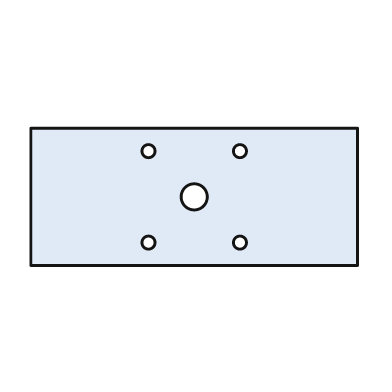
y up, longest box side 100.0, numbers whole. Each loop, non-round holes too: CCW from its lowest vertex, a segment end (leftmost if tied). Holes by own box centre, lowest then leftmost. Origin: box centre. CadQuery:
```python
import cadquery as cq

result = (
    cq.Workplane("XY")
    .moveTo(-50.0, -21.0)
    .lineTo(50.0, -21.0)
    .lineTo(50.0, 21.0)
    .lineTo(-50.0, 21.0)
    .close()
    .moveTo(-14.0, -14.0)
    .circle(2.0)
    .moveTo(14.0, -14.0)
    .circle(2.0)
    .moveTo(0.0, 0.0)
    .circle(4.0)
    .moveTo(-14.0, 14.0)
    .circle(2.0)
    .moveTo(14.0, 14.0)
    .circle(2.0)
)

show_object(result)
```